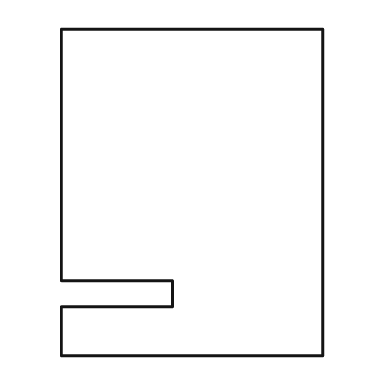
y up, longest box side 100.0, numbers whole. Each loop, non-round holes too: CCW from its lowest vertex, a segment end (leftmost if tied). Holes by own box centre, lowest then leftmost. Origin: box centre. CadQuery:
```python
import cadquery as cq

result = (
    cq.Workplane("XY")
    .moveTo(-40.0, -50.0)
    .lineTo(40.0, -50.0)
    .lineTo(40.0, 50.0)
    .lineTo(-40.0, 50.0)
    .lineTo(-40.0, -27.0)
    .lineTo(-6.0, -27.0)
    .lineTo(-6.0, -35.0)
    .lineTo(-40.0, -35.0)
    .close()
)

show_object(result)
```